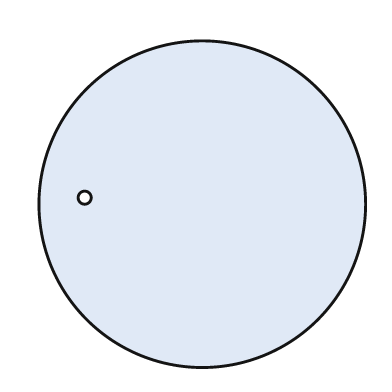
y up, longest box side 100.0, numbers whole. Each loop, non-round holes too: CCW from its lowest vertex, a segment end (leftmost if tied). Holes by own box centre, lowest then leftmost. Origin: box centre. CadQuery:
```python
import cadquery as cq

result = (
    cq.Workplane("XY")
    .moveTo(0.0, 0.0)
    .circle(50.0)
    .moveTo(-36.0, 2.0)
    .circle(2.0)
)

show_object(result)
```